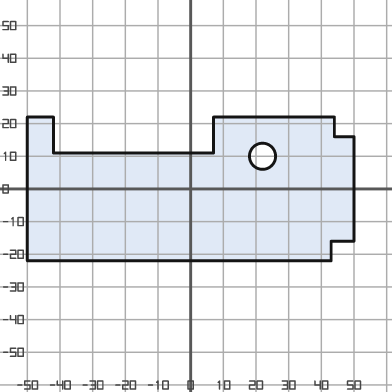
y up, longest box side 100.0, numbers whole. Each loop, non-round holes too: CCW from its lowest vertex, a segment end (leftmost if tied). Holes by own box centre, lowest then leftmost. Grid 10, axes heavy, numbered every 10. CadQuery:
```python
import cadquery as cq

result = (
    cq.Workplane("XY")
    .moveTo(-50.0, -22.0)
    .lineTo(43.0, -22.0)
    .lineTo(43.0, -16.0)
    .lineTo(50.0, -16.0)
    .lineTo(50.0, 16.0)
    .lineTo(44.0, 16.0)
    .lineTo(44.0, 22.0)
    .lineTo(7.0, 22.0)
    .lineTo(7.0, 11.0)
    .lineTo(-42.0, 11.0)
    .lineTo(-42.0, 22.0)
    .lineTo(-50.0, 22.0)
    .close()
    .moveTo(22.0, 10.0)
    .circle(4.0)
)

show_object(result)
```